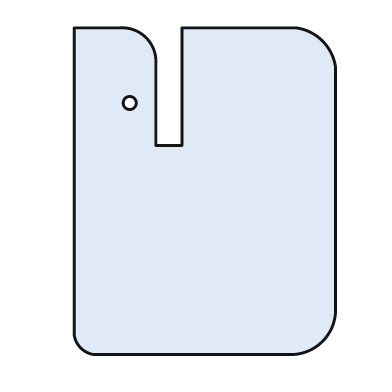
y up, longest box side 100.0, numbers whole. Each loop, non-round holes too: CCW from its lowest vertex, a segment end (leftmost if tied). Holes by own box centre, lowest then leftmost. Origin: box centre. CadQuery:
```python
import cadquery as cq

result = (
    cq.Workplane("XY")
    .moveTo(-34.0, -50.0)
    .lineTo(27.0, -50.0)
    .threePointArc((36.0, -46.0), (40.0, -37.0))
    .lineTo(40.0, 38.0)
    .threePointArc((36.0, 46.0), (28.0, 50.0))
    .lineTo(-7.0, 50.0)
    .lineTo(-7.0, 14.0)
    .lineTo(-15.0, 14.0)
    .lineTo(-15.0, 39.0)
    .threePointArc((-18.0, 47.0), (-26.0, 50.0))
    .lineTo(-40.0, 50.0)
    .lineTo(-40.0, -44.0)
    .threePointArc((-38.0, -48.0), (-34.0, -50.0))
    .close()
    .moveTo(-23.0, 27.0)
    .circle(2.0)
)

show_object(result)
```